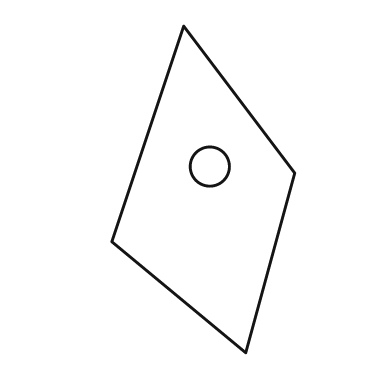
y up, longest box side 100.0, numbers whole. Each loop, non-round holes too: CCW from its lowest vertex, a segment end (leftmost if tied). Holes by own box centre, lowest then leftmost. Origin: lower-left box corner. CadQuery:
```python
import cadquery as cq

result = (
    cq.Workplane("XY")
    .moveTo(41.0, 0.0)
    .lineTo(56.0, 55.0)
    .lineTo(22.0, 100.0)
    .lineTo(0.0, 34.0)
    .close()
    .moveTo(30.0, 57.0)
    .circle(6.0)
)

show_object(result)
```